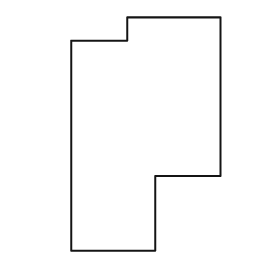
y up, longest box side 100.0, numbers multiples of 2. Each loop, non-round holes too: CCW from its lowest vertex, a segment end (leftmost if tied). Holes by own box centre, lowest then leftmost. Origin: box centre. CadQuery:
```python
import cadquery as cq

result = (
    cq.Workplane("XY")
    .moveTo(-32.0, -50.0)
    .lineTo(4.0, -50.0)
    .lineTo(4.0, -18.0)
    .lineTo(32.0, -18.0)
    .lineTo(32.0, 50.0)
    .lineTo(-8.0, 50.0)
    .lineTo(-8.0, 40.0)
    .lineTo(-32.0, 40.0)
    .close()
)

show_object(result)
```